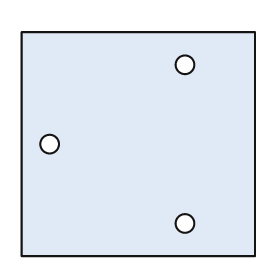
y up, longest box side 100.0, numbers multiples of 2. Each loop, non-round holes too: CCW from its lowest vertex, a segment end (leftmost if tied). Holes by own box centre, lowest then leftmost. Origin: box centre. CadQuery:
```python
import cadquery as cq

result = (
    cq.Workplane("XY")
    .moveTo(-50.0, -48.0)
    .lineTo(50.0, -48.0)
    .lineTo(50.0, 48.0)
    .lineTo(-50.0, 48.0)
    .close()
    .moveTo(20.0, -34.0)
    .circle(4.0)
    .moveTo(-38.0, 0.0)
    .circle(4.0)
    .moveTo(20.0, 34.0)
    .circle(4.0)
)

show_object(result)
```